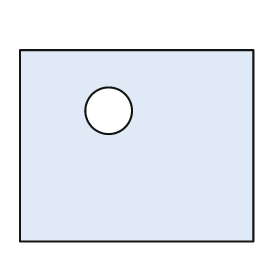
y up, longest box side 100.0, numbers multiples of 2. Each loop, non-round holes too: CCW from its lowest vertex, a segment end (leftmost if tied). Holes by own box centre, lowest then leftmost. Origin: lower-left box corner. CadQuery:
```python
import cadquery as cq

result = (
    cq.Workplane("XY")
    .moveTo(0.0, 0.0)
    .lineTo(100.0, 0.0)
    .lineTo(100.0, 82.0)
    .lineTo(0.0, 82.0)
    .close()
    .moveTo(38.0, 56.0)
    .circle(10.0)
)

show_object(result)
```